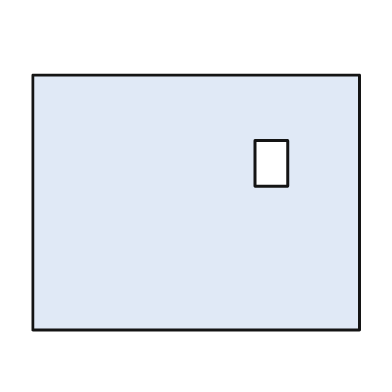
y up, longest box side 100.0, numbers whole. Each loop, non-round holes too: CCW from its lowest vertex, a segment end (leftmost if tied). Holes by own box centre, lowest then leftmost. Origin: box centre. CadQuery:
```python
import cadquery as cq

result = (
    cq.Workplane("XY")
    .moveTo(-50.0, -39.0)
    .lineTo(50.0, -39.0)
    .lineTo(50.0, 39.0)
    .lineTo(-50.0, 39.0)
    .close()
    .moveTo(18.0, 5.0)
    .lineTo(28.0, 5.0)
    .lineTo(28.0, 19.0)
    .lineTo(18.0, 19.0)
    .close()
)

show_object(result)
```